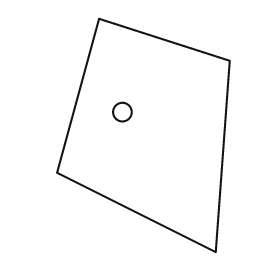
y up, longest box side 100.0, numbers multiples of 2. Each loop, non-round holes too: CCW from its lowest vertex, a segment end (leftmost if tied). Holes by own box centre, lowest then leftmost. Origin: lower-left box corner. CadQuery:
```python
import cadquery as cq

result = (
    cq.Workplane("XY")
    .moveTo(68.0, 0.0)
    .lineTo(74.0, 82.0)
    .lineTo(18.0, 100.0)
    .lineTo(0.0, 34.0)
    .close()
    .moveTo(28.0, 60.0)
    .circle(4.0)
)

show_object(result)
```